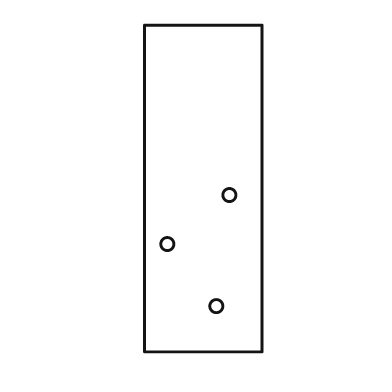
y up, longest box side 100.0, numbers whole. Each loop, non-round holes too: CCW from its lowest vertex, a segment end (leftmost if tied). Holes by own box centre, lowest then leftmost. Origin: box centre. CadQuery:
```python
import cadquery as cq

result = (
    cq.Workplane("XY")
    .moveTo(-18.0, -50.0)
    .lineTo(18.0, -50.0)
    .lineTo(18.0, 50.0)
    .lineTo(-18.0, 50.0)
    .close()
    .moveTo(4.0, -36.0)
    .circle(2.0)
    .moveTo(-11.0, -17.0)
    .circle(2.0)
    .moveTo(8.0, -2.0)
    .circle(2.0)
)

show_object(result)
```